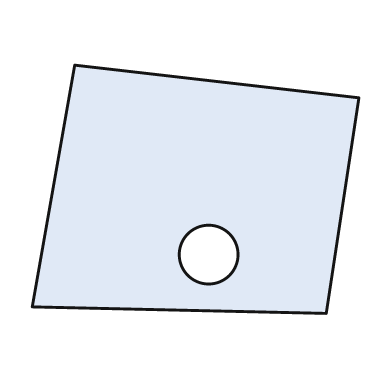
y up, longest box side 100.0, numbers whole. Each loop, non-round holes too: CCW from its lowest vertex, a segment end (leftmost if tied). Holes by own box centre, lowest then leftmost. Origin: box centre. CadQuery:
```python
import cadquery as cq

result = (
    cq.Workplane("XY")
    .moveTo(40.0, -38.0)
    .lineTo(50.0, 28.0)
    .lineTo(-37.0, 38.0)
    .lineTo(-50.0, -36.0)
    .close()
    .moveTo(4.0, -20.0)
    .circle(9.0)
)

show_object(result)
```